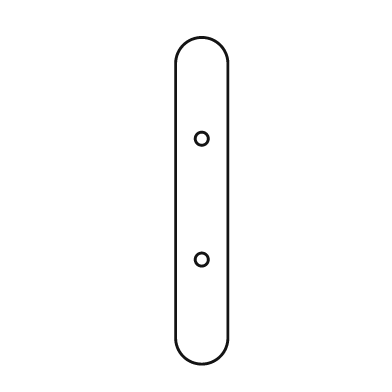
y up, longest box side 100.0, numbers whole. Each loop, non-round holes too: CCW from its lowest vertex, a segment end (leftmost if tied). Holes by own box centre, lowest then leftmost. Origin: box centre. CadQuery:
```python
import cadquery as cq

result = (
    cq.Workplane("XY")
    .moveTo(-8.0, -42.0)
    .threePointArc((0.0, -50.0), (8.0, -42.0))
    .lineTo(8.0, 42.0)
    .threePointArc((0.0, 50.0), (-8.0, 42.0))
    .close()
    .moveTo(0.0, -18.0)
    .circle(2.0)
    .moveTo(0.0, 19.0)
    .circle(2.0)
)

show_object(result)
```